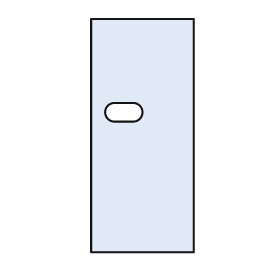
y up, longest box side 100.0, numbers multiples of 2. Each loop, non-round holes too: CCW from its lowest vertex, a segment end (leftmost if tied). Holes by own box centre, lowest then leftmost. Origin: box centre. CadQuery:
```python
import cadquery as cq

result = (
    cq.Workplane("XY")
    .moveTo(-22.0, -50.0)
    .lineTo(22.0, -50.0)
    .lineTo(22.0, 50.0)
    .lineTo(-22.0, 50.0)
    .close()
    .moveTo(-12.0, 6.0)
    .lineTo(-4.0, 6.0)
    .threePointArc((0.0, 10.0), (-4.0, 14.0))
    .lineTo(-12.0, 14.0)
    .threePointArc((-16.0, 10.0), (-12.0, 6.0))
    .close()
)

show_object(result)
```